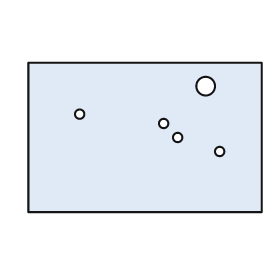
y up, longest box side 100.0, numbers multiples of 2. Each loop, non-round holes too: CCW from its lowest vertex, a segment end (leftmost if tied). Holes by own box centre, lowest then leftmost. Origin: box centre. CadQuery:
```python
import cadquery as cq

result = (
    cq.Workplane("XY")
    .moveTo(-50.0, -32.0)
    .lineTo(50.0, -32.0)
    .lineTo(50.0, 32.0)
    .lineTo(-50.0, 32.0)
    .close()
    .moveTo(32.0, -6.0)
    .circle(2.0)
    .moveTo(14.0, 0.0)
    .circle(2.0)
    .moveTo(8.0, 6.0)
    .circle(2.0)
    .moveTo(-28.0, 10.0)
    .circle(2.0)
    .moveTo(26.0, 22.0)
    .circle(4.0)
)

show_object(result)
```